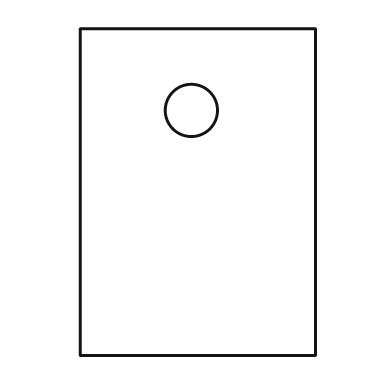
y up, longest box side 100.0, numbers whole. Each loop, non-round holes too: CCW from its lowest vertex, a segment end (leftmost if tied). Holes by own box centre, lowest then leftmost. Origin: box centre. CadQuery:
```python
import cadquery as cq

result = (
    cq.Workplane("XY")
    .moveTo(-36.0, -50.0)
    .lineTo(36.0, -50.0)
    .lineTo(36.0, 50.0)
    .lineTo(-36.0, 50.0)
    .close()
    .moveTo(-2.0, 25.0)
    .circle(8.0)
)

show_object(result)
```